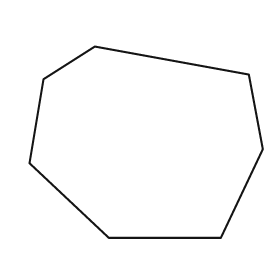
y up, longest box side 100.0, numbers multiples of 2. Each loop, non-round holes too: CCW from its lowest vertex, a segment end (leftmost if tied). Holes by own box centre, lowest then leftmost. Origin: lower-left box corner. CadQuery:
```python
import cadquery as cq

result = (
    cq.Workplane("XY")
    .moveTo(34.0, 0.0)
    .lineTo(82.0, 0.0)
    .lineTo(100.0, 38.0)
    .lineTo(94.0, 70.0)
    .lineTo(28.0, 82.0)
    .lineTo(6.0, 68.0)
    .lineTo(0.0, 32.0)
    .close()
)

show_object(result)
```